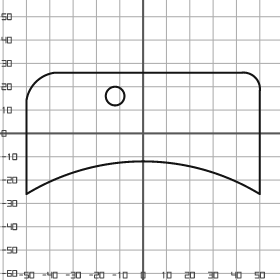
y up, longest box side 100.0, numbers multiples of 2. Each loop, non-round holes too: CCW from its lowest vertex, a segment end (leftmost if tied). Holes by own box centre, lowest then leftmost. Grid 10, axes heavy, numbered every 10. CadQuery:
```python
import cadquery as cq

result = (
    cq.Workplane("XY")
    .moveTo(-50.0, -26.0)
    .threePointArc((0.0, -12.0), (50.0, -26.0))
    .lineTo(50.0, 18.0)
    .threePointArc((48.0, 24.0), (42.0, 26.0))
    .lineTo(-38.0, 26.0)
    .threePointArc((-46.0, 22.0), (-50.0, 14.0))
    .close()
    .moveTo(-12.0, 16.0)
    .circle(4.0)
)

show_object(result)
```